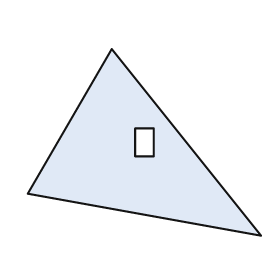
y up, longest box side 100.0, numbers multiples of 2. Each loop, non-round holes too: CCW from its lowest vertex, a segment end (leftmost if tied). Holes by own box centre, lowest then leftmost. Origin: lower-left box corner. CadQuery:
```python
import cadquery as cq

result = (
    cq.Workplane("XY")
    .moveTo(100.0, 0.0)
    .lineTo(36.0, 80.0)
    .lineTo(0.0, 18.0)
    .close()
    .moveTo(46.0, 34.0)
    .lineTo(54.0, 34.0)
    .lineTo(54.0, 46.0)
    .lineTo(46.0, 46.0)
    .close()
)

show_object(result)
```